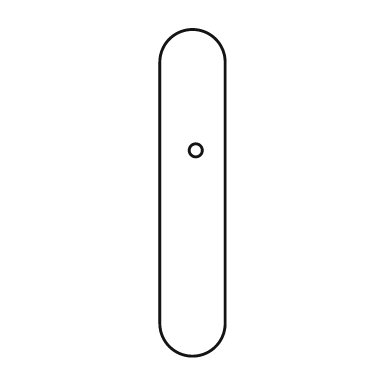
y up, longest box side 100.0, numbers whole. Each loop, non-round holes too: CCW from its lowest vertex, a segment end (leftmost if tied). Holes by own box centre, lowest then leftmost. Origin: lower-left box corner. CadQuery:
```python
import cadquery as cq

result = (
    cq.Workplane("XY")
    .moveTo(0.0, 10.0)
    .threePointArc((10.0, 0.0), (20.0, 10.0))
    .lineTo(20.0, 90.0)
    .threePointArc((10.0, 100.0), (0.0, 90.0))
    .close()
    .moveTo(11.0, 63.0)
    .circle(2.0)
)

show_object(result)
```